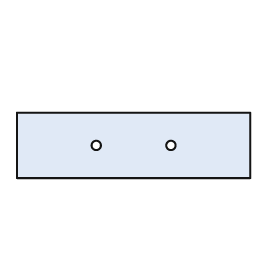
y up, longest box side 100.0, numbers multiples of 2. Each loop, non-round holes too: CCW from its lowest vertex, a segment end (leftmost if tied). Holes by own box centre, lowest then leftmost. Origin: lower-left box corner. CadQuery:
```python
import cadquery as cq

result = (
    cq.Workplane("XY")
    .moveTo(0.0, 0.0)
    .lineTo(100.0, 0.0)
    .lineTo(100.0, 28.0)
    .lineTo(0.0, 28.0)
    .close()
    .moveTo(34.0, 14.0)
    .circle(2.0)
    .moveTo(66.0, 14.0)
    .circle(2.0)
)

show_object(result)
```